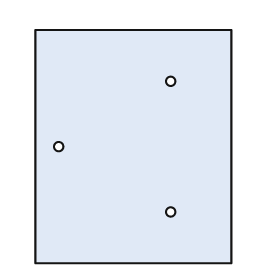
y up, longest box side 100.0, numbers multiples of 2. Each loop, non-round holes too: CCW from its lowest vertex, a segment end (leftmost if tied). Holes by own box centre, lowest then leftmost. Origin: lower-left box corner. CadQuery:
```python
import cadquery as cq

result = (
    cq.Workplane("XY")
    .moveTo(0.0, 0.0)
    .lineTo(84.0, 0.0)
    .lineTo(84.0, 100.0)
    .lineTo(0.0, 100.0)
    .close()
    .moveTo(58.0, 22.0)
    .circle(2.0)
    .moveTo(10.0, 50.0)
    .circle(2.0)
    .moveTo(58.0, 78.0)
    .circle(2.0)
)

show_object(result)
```